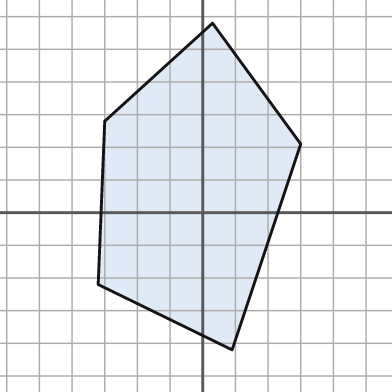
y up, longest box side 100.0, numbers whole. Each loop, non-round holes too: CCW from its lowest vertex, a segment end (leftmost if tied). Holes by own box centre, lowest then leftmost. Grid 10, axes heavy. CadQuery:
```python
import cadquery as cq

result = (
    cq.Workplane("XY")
    .moveTo(9.0, -42.0)
    .lineTo(30.0, 21.0)
    .lineTo(3.0, 58.0)
    .lineTo(-30.0, 28.0)
    .lineTo(-32.0, -22.0)
    .close()
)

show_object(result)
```